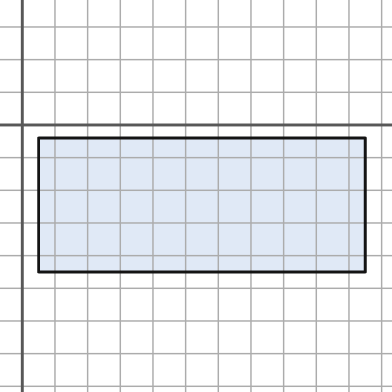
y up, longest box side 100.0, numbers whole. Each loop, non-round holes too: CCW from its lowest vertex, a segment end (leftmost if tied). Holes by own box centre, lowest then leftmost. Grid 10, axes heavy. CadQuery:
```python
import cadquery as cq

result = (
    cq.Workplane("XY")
    .moveTo(5.0, -45.0)
    .lineTo(105.0, -45.0)
    .lineTo(105.0, -4.0)
    .lineTo(5.0, -4.0)
    .close()
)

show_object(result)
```